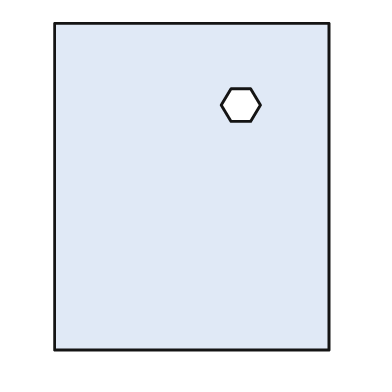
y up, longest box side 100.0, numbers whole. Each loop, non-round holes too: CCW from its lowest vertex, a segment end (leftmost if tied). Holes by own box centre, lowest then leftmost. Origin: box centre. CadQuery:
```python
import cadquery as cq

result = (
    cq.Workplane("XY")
    .moveTo(-42.0, -50.0)
    .lineTo(42.0, -50.0)
    .lineTo(42.0, 50.0)
    .lineTo(-42.0, 50.0)
    .close()
    .moveTo(12.0, 20.0)
    .lineTo(18.0, 20.0)
    .lineTo(21.0, 25.0)
    .lineTo(18.0, 30.0)
    .lineTo(12.0, 30.0)
    .lineTo(9.0, 25.0)
    .close()
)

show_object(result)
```